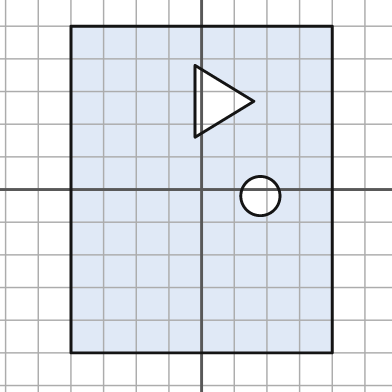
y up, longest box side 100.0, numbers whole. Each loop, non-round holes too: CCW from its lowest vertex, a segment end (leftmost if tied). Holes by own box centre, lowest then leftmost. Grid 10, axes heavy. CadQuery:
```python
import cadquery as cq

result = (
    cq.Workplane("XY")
    .moveTo(-40.0, -50.0)
    .lineTo(40.0, -50.0)
    .lineTo(40.0, 50.0)
    .lineTo(-40.0, 50.0)
    .close()
    .moveTo(18.0, -2.0)
    .circle(6.0)
    .moveTo(-2.0, 16.0)
    .lineTo(16.0, 27.0)
    .lineTo(-2.0, 38.0)
    .close()
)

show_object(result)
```